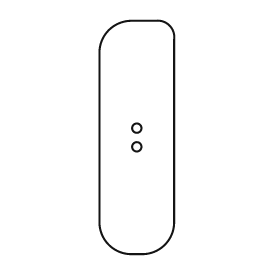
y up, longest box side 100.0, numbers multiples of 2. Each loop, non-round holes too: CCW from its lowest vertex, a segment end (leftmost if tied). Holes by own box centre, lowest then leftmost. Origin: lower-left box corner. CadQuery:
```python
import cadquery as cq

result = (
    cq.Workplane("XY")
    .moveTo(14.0, 0.0)
    .lineTo(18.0, 0.0)
    .threePointArc((28.0, 4.0), (32.0, 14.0))
    .lineTo(32.0, 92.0)
    .threePointArc((30.0, 98.0), (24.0, 100.0))
    .lineTo(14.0, 100.0)
    .threePointArc((4.0, 96.0), (0.0, 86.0))
    .lineTo(0.0, 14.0)
    .threePointArc((4.0, 4.0), (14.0, 0.0))
    .close()
    .moveTo(16.0, 46.0)
    .circle(2.0)
    .moveTo(16.0, 54.0)
    .circle(2.0)
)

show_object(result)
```